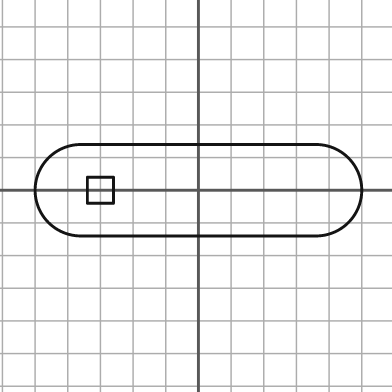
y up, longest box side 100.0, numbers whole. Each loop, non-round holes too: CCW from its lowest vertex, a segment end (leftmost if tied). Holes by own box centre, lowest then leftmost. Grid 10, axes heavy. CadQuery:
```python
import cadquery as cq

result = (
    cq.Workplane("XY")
    .moveTo(-36.0, -14.0)
    .lineTo(36.0, -14.0)
    .threePointArc((50.0, 0.0), (36.0, 14.0))
    .lineTo(-36.0, 14.0)
    .threePointArc((-50.0, 0.0), (-36.0, -14.0))
    .close()
    .moveTo(-34.0, -4.0)
    .lineTo(-26.0, -4.0)
    .lineTo(-26.0, 4.0)
    .lineTo(-34.0, 4.0)
    .close()
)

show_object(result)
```